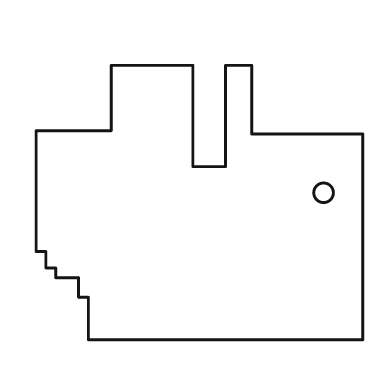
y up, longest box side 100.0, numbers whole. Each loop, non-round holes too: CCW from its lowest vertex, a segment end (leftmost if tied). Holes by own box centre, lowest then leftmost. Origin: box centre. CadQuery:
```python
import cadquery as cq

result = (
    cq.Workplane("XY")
    .moveTo(-34.0, -42.0)
    .lineTo(50.0, -42.0)
    .lineTo(50.0, 21.0)
    .lineTo(16.0, 21.0)
    .lineTo(16.0, 42.0)
    .lineTo(8.0, 42.0)
    .lineTo(8.0, 11.0)
    .lineTo(-2.0, 11.0)
    .lineTo(-2.0, 42.0)
    .lineTo(-27.0, 42.0)
    .lineTo(-27.0, 22.0)
    .lineTo(-50.0, 22.0)
    .lineTo(-50.0, -15.0)
    .lineTo(-47.0, -15.0)
    .lineTo(-47.0, -20.0)
    .lineTo(-44.0, -20.0)
    .lineTo(-44.0, -23.0)
    .lineTo(-37.0, -23.0)
    .lineTo(-37.0, -29.0)
    .lineTo(-34.0, -29.0)
    .close()
    .moveTo(38.0, 3.0)
    .circle(3.0)
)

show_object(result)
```